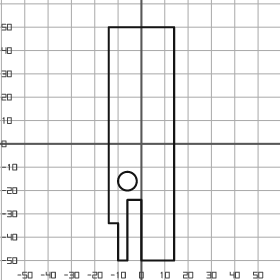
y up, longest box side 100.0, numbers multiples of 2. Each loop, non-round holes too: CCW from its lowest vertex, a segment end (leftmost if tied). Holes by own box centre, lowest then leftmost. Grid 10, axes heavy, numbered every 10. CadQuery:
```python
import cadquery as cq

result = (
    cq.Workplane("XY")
    .moveTo(-10.0, -50.0)
    .lineTo(-6.0, -50.0)
    .lineTo(-6.0, -24.0)
    .lineTo(0.0, -24.0)
    .lineTo(0.0, -50.0)
    .lineTo(14.0, -50.0)
    .lineTo(14.0, 50.0)
    .lineTo(-14.0, 50.0)
    .lineTo(-14.0, -34.0)
    .lineTo(-10.0, -34.0)
    .close()
    .moveTo(-6.0, -16.0)
    .circle(4.0)
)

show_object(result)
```